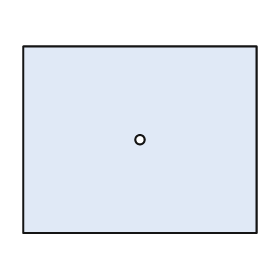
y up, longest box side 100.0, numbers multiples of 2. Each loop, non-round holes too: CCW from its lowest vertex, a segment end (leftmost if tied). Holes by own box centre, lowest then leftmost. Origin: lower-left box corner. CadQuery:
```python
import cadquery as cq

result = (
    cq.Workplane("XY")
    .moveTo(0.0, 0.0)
    .lineTo(100.0, 0.0)
    .lineTo(100.0, 80.0)
    .lineTo(0.0, 80.0)
    .close()
    .moveTo(50.0, 40.0)
    .circle(2.0)
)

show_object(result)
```